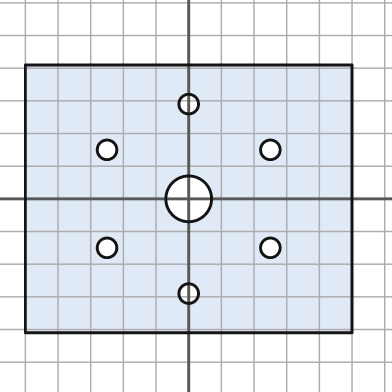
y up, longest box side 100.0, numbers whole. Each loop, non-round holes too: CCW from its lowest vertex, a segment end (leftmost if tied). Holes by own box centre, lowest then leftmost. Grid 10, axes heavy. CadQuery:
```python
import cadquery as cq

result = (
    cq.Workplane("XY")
    .moveTo(-50.0, -41.0)
    .lineTo(50.0, -41.0)
    .lineTo(50.0, 41.0)
    .lineTo(-50.0, 41.0)
    .close()
    .moveTo(0.0, -29.0)
    .circle(3.0)
    .moveTo(-25.0, -15.0)
    .circle(3.0)
    .moveTo(25.0, -15.0)
    .circle(3.0)
    .moveTo(0.0, 0.0)
    .circle(7.0)
    .moveTo(-25.0, 15.0)
    .circle(3.0)
    .moveTo(25.0, 15.0)
    .circle(3.0)
    .moveTo(0.0, 29.0)
    .circle(3.0)
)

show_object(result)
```